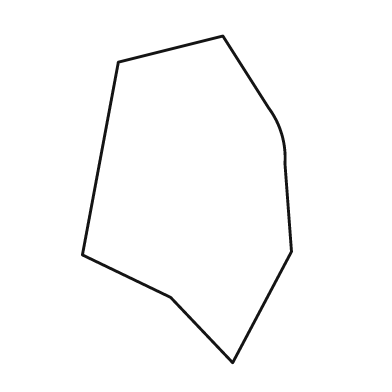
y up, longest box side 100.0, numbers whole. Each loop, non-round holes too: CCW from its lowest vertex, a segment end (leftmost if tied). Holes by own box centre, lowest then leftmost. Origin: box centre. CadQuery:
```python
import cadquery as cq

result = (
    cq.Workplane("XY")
    .moveTo(14.0, -50.0)
    .lineTo(32.0, -16.0)
    .lineTo(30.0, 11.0)
    .threePointArc((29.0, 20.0), (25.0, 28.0))
    .lineTo(11.0, 50.0)
    .lineTo(-21.0, 42.0)
    .lineTo(-32.0, -17.0)
    .lineTo(-5.0, -30.0)
    .close()
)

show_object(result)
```